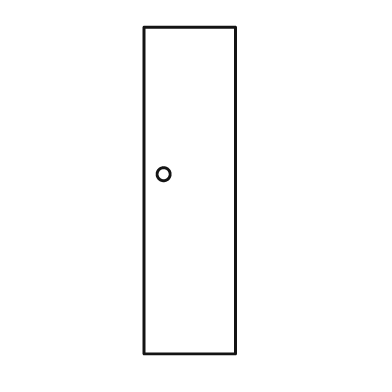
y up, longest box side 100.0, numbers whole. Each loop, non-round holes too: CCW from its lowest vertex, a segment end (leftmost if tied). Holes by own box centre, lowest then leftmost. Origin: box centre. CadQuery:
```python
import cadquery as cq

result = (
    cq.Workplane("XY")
    .moveTo(-14.0, -50.0)
    .lineTo(14.0, -50.0)
    .lineTo(14.0, 50.0)
    .lineTo(-14.0, 50.0)
    .close()
    .moveTo(-8.0, 5.0)
    .circle(2.0)
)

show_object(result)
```